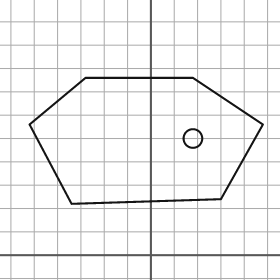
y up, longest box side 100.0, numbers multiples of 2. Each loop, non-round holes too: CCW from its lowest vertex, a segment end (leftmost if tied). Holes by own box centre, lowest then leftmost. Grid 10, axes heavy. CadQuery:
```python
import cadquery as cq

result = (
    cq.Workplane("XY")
    .moveTo(-34.0, 22.0)
    .lineTo(30.0, 24.0)
    .lineTo(48.0, 56.0)
    .lineTo(18.0, 76.0)
    .lineTo(-28.0, 76.0)
    .lineTo(-52.0, 56.0)
    .close()
    .moveTo(18.0, 50.0)
    .circle(4.0)
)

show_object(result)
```